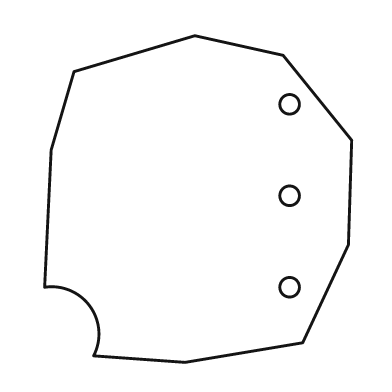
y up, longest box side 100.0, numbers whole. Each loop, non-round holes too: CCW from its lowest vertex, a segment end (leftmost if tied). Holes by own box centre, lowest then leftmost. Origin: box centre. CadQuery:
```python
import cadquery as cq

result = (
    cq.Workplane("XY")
    .moveTo(-4.0, -50.0)
    .lineTo(32.0, -44.0)
    .lineTo(46.0, -14.0)
    .lineTo(47.0, 18.0)
    .lineTo(26.0, 44.0)
    .lineTo(-1.0, 50.0)
    .lineTo(-38.0, 39.0)
    .lineTo(-45.0, 15.0)
    .lineTo(-47.0, -27.0)
    .threePointArc((-33.0, -33.0), (-32.0, -48.0))
    .close()
    .moveTo(28.0, -27.0)
    .circle(3.0)
    .moveTo(28.0, 1.0)
    .circle(3.0)
    .moveTo(28.0, 29.0)
    .circle(3.0)
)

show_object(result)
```